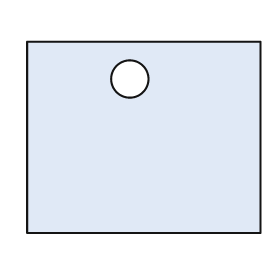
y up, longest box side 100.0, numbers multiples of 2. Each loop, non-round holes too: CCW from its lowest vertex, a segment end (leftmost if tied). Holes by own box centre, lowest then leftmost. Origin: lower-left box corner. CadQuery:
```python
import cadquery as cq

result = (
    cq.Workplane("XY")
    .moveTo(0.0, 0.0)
    .lineTo(100.0, 0.0)
    .lineTo(100.0, 82.0)
    .lineTo(0.0, 82.0)
    .close()
    .moveTo(44.0, 66.0)
    .circle(8.0)
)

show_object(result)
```